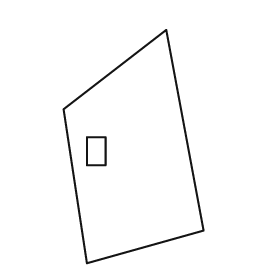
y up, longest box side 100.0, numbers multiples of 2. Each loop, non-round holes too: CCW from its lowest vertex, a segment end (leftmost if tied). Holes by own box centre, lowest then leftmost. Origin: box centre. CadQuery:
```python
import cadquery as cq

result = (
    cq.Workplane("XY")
    .moveTo(-20.0, -50.0)
    .lineTo(30.0, -36.0)
    .lineTo(14.0, 50.0)
    .lineTo(-30.0, 16.0)
    .close()
    .moveTo(-20.0, -8.0)
    .lineTo(-12.0, -8.0)
    .lineTo(-12.0, 4.0)
    .lineTo(-20.0, 4.0)
    .close()
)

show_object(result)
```